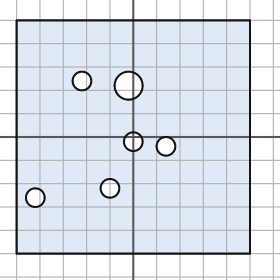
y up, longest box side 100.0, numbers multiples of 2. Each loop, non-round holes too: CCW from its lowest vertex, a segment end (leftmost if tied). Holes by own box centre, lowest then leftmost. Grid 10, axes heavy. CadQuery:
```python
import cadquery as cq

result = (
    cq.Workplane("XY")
    .moveTo(-50.0, -50.0)
    .lineTo(50.0, -50.0)
    .lineTo(50.0, 50.0)
    .lineTo(-50.0, 50.0)
    .close()
    .moveTo(-42.0, -26.0)
    .circle(4.0)
    .moveTo(-10.0, -22.0)
    .circle(4.0)
    .moveTo(14.0, -4.0)
    .circle(4.0)
    .moveTo(0.0, -2.0)
    .circle(4.0)
    .moveTo(-2.0, 22.0)
    .circle(6.0)
    .moveTo(-22.0, 24.0)
    .circle(4.0)
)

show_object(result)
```